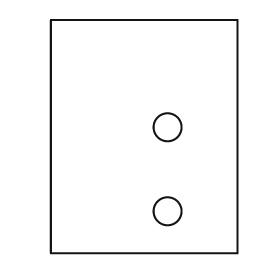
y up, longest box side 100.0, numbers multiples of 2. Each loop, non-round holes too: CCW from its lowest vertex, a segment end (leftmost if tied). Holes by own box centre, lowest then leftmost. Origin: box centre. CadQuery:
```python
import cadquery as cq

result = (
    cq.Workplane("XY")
    .moveTo(-40.0, -50.0)
    .lineTo(40.0, -50.0)
    .lineTo(40.0, 50.0)
    .lineTo(-40.0, 50.0)
    .close()
    .moveTo(10.0, -32.0)
    .circle(6.0)
    .moveTo(10.0, 4.0)
    .circle(6.0)
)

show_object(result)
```